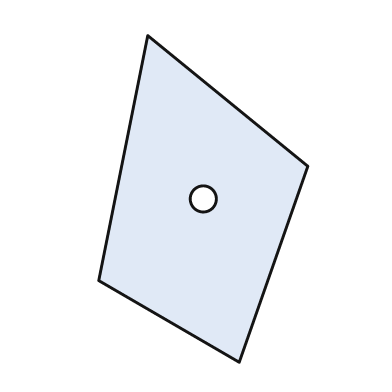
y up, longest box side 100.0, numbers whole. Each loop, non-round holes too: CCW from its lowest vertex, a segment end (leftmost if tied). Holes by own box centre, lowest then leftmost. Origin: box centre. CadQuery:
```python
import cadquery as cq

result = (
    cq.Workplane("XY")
    .moveTo(11.0, -50.0)
    .lineTo(32.0, 10.0)
    .lineTo(-17.0, 50.0)
    .lineTo(-32.0, -25.0)
    .close()
    .moveTo(0.0, 0.0)
    .circle(4.0)
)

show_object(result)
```